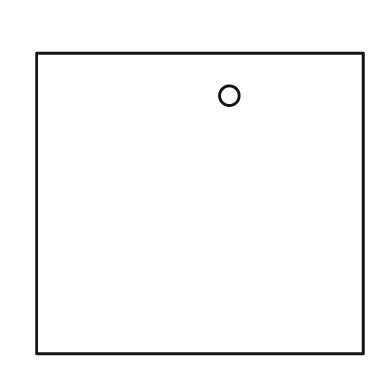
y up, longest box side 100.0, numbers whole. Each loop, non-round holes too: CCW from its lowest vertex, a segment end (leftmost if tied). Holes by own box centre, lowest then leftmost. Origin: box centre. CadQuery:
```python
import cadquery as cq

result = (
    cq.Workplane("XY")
    .moveTo(-50.0, -46.0)
    .lineTo(50.0, -46.0)
    .lineTo(50.0, 46.0)
    .lineTo(-50.0, 46.0)
    .close()
    .moveTo(9.0, 33.0)
    .circle(3.0)
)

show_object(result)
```